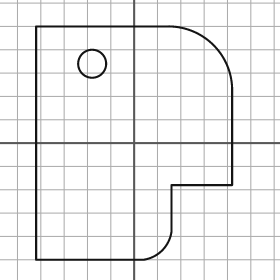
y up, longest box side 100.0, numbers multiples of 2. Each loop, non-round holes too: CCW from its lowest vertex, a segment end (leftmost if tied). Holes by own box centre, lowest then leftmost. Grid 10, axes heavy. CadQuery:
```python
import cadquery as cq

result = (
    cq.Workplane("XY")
    .moveTo(-42.0, -50.0)
    .lineTo(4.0, -50.0)
    .threePointArc((12.0, -46.0), (16.0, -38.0))
    .lineTo(16.0, -18.0)
    .lineTo(42.0, -18.0)
    .lineTo(42.0, 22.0)
    .threePointArc((34.0, 42.0), (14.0, 50.0))
    .lineTo(-42.0, 50.0)
    .close()
    .moveTo(-18.0, 34.0)
    .circle(6.0)
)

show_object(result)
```